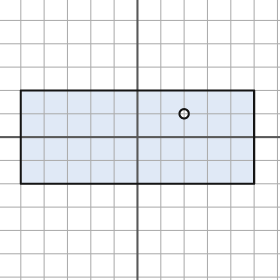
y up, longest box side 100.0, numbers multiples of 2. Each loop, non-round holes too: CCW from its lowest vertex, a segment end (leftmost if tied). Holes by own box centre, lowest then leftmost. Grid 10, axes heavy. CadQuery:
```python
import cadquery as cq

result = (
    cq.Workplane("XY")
    .moveTo(-50.0, -20.0)
    .lineTo(50.0, -20.0)
    .lineTo(50.0, 20.0)
    .lineTo(-50.0, 20.0)
    .close()
    .moveTo(20.0, 10.0)
    .circle(2.0)
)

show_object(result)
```